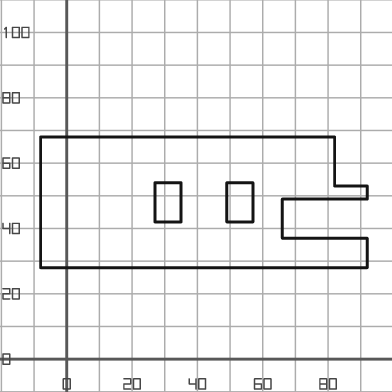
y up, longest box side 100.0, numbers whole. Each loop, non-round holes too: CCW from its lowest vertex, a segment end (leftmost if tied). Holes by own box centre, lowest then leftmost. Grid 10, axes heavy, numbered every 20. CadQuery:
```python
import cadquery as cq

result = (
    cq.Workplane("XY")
    .moveTo(-8.0, 28.0)
    .lineTo(92.0, 28.0)
    .lineTo(92.0, 37.0)
    .lineTo(66.0, 37.0)
    .lineTo(66.0, 49.0)
    .lineTo(92.0, 49.0)
    .lineTo(92.0, 53.0)
    .lineTo(82.0, 53.0)
    .lineTo(82.0, 68.0)
    .lineTo(-8.0, 68.0)
    .close()
    .moveTo(27.0, 42.0)
    .lineTo(35.0, 42.0)
    .lineTo(35.0, 54.0)
    .lineTo(27.0, 54.0)
    .close()
    .moveTo(49.0, 42.0)
    .lineTo(57.0, 42.0)
    .lineTo(57.0, 54.0)
    .lineTo(49.0, 54.0)
    .close()
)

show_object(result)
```